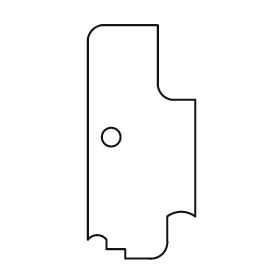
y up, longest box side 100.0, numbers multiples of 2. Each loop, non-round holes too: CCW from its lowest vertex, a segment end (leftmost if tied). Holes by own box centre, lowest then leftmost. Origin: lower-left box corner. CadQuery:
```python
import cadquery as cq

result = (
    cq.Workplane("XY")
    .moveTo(16.0, 0.0)
    .lineTo(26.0, 0.0)
    .threePointArc((32.0, 2.0), (34.0, 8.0))
    .lineTo(34.0, 18.0)
    .threePointArc((40.0, 20.0), (46.0, 18.0))
    .lineTo(46.0, 68.0)
    .lineTo(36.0, 68.0)
    .threePointArc((32.0, 70.0), (30.0, 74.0))
    .lineTo(30.0, 100.0)
    .lineTo(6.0, 100.0)
    .threePointArc((2.0, 98.0), (0.0, 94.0))
    .lineTo(0.0, 8.0)
    .threePointArc((4.0, 10.0), (8.0, 8.0))
    .lineTo(8.0, 4.0)
    .lineTo(16.0, 4.0)
    .close()
    .moveTo(10.0, 52.0)
    .circle(4.0)
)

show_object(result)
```